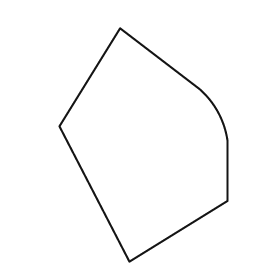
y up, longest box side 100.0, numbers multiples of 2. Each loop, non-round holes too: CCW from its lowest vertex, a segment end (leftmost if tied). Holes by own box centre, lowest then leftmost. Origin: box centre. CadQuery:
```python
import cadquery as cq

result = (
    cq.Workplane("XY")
    .moveTo(-6.0, -50.0)
    .lineTo(36.0, -24.0)
    .lineTo(36.0, 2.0)
    .threePointArc((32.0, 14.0), (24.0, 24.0))
    .lineTo(-10.0, 50.0)
    .lineTo(-36.0, 8.0)
    .close()
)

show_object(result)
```